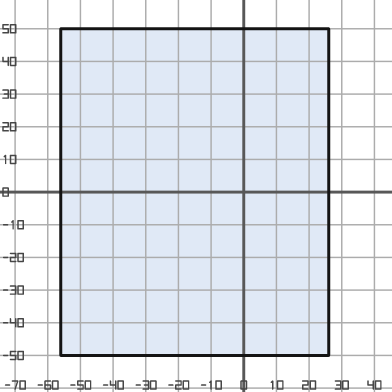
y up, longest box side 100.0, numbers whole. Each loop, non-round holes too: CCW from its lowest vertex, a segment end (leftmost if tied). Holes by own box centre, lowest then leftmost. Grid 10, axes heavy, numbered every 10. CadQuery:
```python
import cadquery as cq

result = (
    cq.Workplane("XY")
    .moveTo(-56.0, -50.0)
    .lineTo(26.0, -50.0)
    .lineTo(26.0, 50.0)
    .lineTo(-56.0, 50.0)
    .close()
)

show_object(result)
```